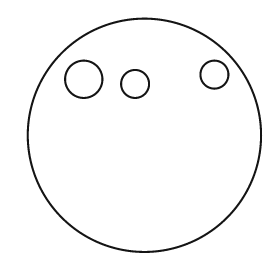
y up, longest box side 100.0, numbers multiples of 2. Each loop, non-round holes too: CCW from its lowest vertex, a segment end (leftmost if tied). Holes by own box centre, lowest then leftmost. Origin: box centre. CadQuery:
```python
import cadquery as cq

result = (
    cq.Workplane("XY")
    .moveTo(0.0, 0.0)
    .circle(50.0)
    .moveTo(-4.0, 22.0)
    .circle(6.0)
    .moveTo(-26.0, 24.0)
    .circle(8.0)
    .moveTo(30.0, 26.0)
    .circle(6.0)
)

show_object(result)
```